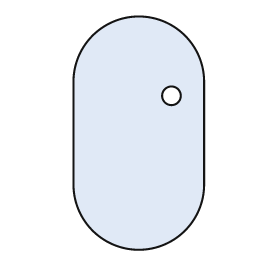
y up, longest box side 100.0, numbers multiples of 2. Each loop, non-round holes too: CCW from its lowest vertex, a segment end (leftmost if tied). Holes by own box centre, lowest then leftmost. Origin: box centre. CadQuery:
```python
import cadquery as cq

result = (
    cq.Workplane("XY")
    .moveTo(-28.0, -22.0)
    .threePointArc((0.0, -50.0), (28.0, -22.0))
    .lineTo(28.0, 22.0)
    .threePointArc((0.0, 50.0), (-28.0, 22.0))
    .close()
    .moveTo(14.0, 16.0)
    .circle(4.0)
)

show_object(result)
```